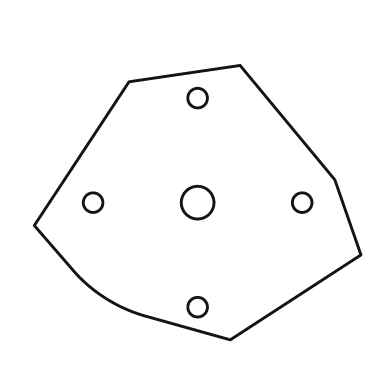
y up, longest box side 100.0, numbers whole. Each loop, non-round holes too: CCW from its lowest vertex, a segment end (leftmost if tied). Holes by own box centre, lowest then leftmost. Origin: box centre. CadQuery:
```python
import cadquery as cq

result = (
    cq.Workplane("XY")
    .moveTo(10.0, -42.0)
    .lineTo(50.0, -16.0)
    .lineTo(42.0, 7.0)
    .lineTo(13.0, 42.0)
    .lineTo(-21.0, 37.0)
    .lineTo(-50.0, -7.0)
    .lineTo(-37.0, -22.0)
    .threePointArc((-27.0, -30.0), (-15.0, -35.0))
    .close()
    .moveTo(0.0, -32.0)
    .circle(3.0)
    .moveTo(-32.0, 0.0)
    .circle(3.0)
    .moveTo(0.0, 0.0)
    .circle(5.0)
    .moveTo(32.0, 0.0)
    .circle(3.0)
    .moveTo(0.0, 32.0)
    .circle(3.0)
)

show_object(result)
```